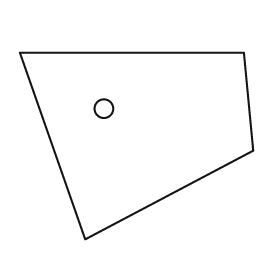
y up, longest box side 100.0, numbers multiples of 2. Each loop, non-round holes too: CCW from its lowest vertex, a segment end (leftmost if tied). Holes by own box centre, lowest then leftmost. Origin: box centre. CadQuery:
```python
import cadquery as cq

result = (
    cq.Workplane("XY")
    .moveTo(-22.0, -40.0)
    .lineTo(50.0, -2.0)
    .lineTo(46.0, 40.0)
    .lineTo(-50.0, 40.0)
    .close()
    .moveTo(-14.0, 16.0)
    .circle(4.0)
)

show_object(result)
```